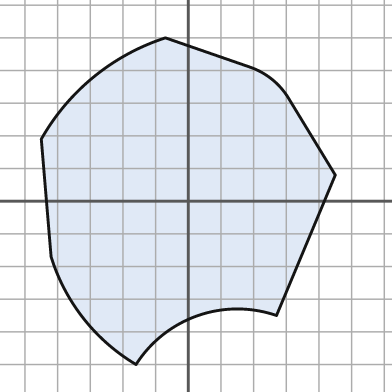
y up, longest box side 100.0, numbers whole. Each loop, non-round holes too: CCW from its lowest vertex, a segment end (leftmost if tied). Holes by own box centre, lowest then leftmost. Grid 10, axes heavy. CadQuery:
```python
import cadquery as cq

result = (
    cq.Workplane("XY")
    .moveTo(-16.0, -50.0)
    .threePointArc((3.0, -35.0), (27.0, -35.0))
    .lineTo(45.0, 8.0)
    .lineTo(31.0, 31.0)
    .threePointArc((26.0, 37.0), (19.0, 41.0))
    .lineTo(-7.0, 50.0)
    .threePointArc((-29.0, 38.0), (-45.0, 19.0))
    .lineTo(-42.0, -17.0)
    .threePointArc((-32.0, -36.0), (-16.0, -50.0))
    .close()
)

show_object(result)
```